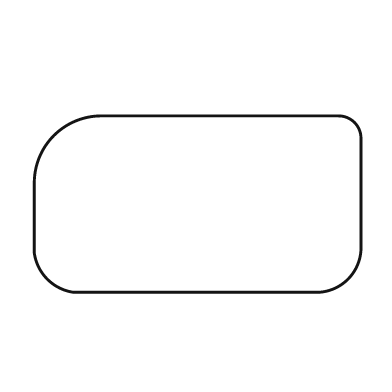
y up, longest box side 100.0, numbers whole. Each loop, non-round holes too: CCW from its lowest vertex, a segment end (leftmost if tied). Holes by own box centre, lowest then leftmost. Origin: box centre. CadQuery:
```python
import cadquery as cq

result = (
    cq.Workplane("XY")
    .moveTo(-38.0, -27.0)
    .lineTo(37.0, -27.0)
    .threePointArc((46.0, -23.0), (50.0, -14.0))
    .lineTo(50.0, 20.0)
    .threePointArc((48.0, 25.0), (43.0, 27.0))
    .lineTo(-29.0, 27.0)
    .threePointArc((-44.0, 21.0), (-50.0, 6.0))
    .lineTo(-50.0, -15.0)
    .threePointArc((-46.0, -23.0), (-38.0, -27.0))
    .close()
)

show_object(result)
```